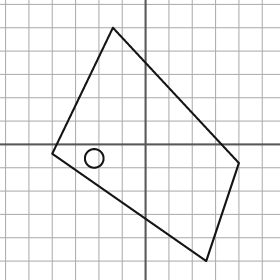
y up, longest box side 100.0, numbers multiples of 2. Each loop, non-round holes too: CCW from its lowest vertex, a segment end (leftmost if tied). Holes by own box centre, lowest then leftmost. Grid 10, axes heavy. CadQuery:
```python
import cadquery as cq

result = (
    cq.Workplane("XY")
    .moveTo(26.0, -50.0)
    .lineTo(40.0, -8.0)
    .lineTo(-14.0, 50.0)
    .lineTo(-40.0, -4.0)
    .close()
    .moveTo(-22.0, -6.0)
    .circle(4.0)
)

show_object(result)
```